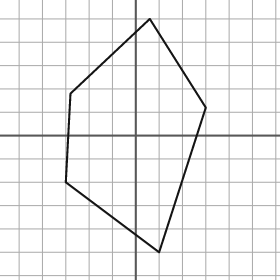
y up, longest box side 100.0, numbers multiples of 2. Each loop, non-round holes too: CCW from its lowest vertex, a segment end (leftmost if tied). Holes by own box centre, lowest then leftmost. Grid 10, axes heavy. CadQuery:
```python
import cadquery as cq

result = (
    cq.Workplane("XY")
    .moveTo(10.0, -50.0)
    .lineTo(30.0, 12.0)
    .lineTo(6.0, 50.0)
    .lineTo(-28.0, 18.0)
    .lineTo(-30.0, -20.0)
    .close()
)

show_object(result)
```